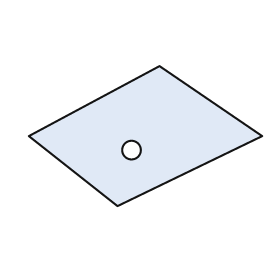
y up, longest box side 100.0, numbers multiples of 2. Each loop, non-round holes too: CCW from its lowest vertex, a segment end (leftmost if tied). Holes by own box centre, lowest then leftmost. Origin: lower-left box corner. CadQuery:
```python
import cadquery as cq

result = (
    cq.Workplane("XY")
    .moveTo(38.0, 0.0)
    .lineTo(100.0, 30.0)
    .lineTo(56.0, 60.0)
    .lineTo(0.0, 30.0)
    .close()
    .moveTo(44.0, 24.0)
    .circle(4.0)
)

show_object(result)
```